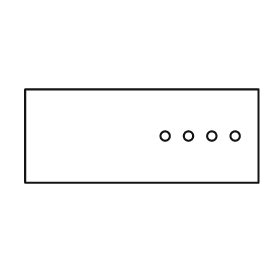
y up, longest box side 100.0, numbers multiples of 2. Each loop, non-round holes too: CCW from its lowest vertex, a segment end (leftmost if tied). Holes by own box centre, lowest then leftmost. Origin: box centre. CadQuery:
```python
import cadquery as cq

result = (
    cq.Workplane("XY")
    .moveTo(-50.0, -20.0)
    .lineTo(50.0, -20.0)
    .lineTo(50.0, 20.0)
    .lineTo(-50.0, 20.0)
    .close()
    .moveTo(10.0, 0.0)
    .circle(2.0)
    .moveTo(20.0, 0.0)
    .circle(2.0)
    .moveTo(30.0, 0.0)
    .circle(2.0)
    .moveTo(40.0, 0.0)
    .circle(2.0)
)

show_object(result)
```